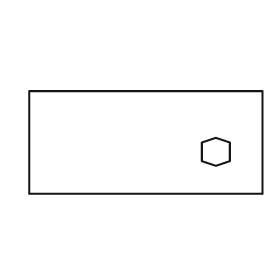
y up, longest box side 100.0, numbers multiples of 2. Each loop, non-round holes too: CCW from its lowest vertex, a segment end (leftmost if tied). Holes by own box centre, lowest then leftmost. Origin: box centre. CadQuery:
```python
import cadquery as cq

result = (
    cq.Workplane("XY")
    .moveTo(-50.0, -22.0)
    .lineTo(50.0, -22.0)
    .lineTo(50.0, 22.0)
    .lineTo(-50.0, 22.0)
    .close()
    .moveTo(30.0, -10.0)
    .lineTo(36.0, -8.0)
    .lineTo(36.0, 0.0)
    .lineTo(30.0, 2.0)
    .lineTo(24.0, 0.0)
    .lineTo(24.0, -8.0)
    .close()
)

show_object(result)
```